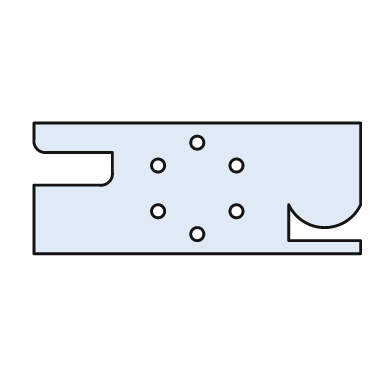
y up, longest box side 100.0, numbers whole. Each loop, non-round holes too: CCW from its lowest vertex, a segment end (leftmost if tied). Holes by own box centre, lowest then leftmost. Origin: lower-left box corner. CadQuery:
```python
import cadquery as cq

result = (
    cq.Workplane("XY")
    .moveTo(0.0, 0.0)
    .lineTo(100.0, 0.0)
    .lineTo(100.0, 4.0)
    .lineTo(78.0, 4.0)
    .lineTo(78.0, 15.0)
    .threePointArc((89.0, 8.0), (100.0, 15.0))
    .lineTo(100.0, 40.0)
    .lineTo(0.0, 40.0)
    .lineTo(0.0, 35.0)
    .threePointArc((1.0, 32.0), (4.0, 31.0))
    .lineTo(24.0, 31.0)
    .lineTo(24.0, 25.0)
    .threePointArc((23.0, 22.0), (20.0, 21.0))
    .lineTo(0.0, 21.0)
    .close()
    .moveTo(50.0, 6.0)
    .circle(2.0)
    .moveTo(38.0, 13.0)
    .circle(2.0)
    .moveTo(62.0, 13.0)
    .circle(2.0)
    .moveTo(38.0, 27.0)
    .circle(2.0)
    .moveTo(62.0, 27.0)
    .circle(2.0)
    .moveTo(50.0, 34.0)
    .circle(2.0)
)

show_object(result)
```